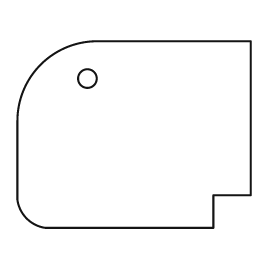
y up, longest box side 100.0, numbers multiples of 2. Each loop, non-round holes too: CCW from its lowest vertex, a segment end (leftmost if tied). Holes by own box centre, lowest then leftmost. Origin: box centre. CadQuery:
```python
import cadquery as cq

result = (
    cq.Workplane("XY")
    .moveTo(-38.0, -40.0)
    .lineTo(34.0, -40.0)
    .lineTo(34.0, -26.0)
    .lineTo(50.0, -26.0)
    .lineTo(50.0, 40.0)
    .lineTo(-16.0, 40.0)
    .threePointArc((-40.0, 30.0), (-50.0, 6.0))
    .lineTo(-50.0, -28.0)
    .threePointArc((-46.0, -36.0), (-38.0, -40.0))
    .close()
    .moveTo(-20.0, 24.0)
    .circle(4.0)
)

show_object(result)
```